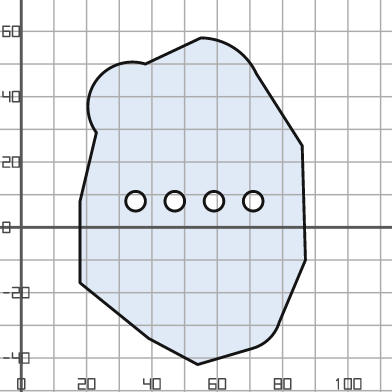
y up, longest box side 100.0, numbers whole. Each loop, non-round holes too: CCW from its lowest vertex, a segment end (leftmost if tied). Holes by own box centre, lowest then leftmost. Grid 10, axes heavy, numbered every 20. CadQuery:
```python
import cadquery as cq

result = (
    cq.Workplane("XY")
    .moveTo(54.0, -42.0)
    .lineTo(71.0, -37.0)
    .threePointArc((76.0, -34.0), (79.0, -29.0))
    .lineTo(87.0, -10.0)
    .lineTo(86.0, 25.0)
    .lineTo(72.0, 47.0)
    .threePointArc((65.0, 55.0), (55.0, 58.0))
    .lineTo(38.0, 50.0)
    .threePointArc((23.0, 45.0), (23.0, 29.0))
    .lineTo(18.0, 8.0)
    .lineTo(18.0, -17.0)
    .lineTo(39.0, -34.0)
    .close()
    .moveTo(35.0, 8.0)
    .circle(3.0)
    .moveTo(47.0, 8.0)
    .circle(3.0)
    .moveTo(59.0, 8.0)
    .circle(3.0)
    .moveTo(71.0, 8.0)
    .circle(3.0)
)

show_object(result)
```